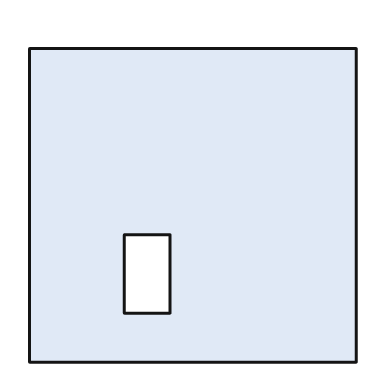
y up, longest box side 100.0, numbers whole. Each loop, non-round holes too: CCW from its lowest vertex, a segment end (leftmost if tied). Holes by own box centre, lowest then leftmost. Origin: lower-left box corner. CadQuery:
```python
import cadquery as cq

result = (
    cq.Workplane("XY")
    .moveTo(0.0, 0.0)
    .lineTo(100.0, 0.0)
    .lineTo(100.0, 96.0)
    .lineTo(0.0, 96.0)
    .close()
    .moveTo(29.0, 15.0)
    .lineTo(43.0, 15.0)
    .lineTo(43.0, 39.0)
    .lineTo(29.0, 39.0)
    .close()
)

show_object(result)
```